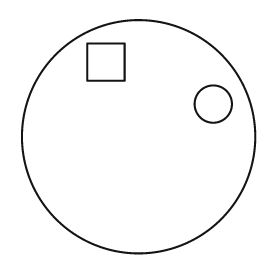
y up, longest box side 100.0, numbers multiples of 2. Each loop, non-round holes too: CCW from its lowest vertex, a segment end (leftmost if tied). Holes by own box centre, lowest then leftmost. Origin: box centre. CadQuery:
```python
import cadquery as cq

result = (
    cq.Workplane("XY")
    .moveTo(0.0, 0.0)
    .circle(50.0)
    .moveTo(32.0, 14.0)
    .circle(8.0)
    .moveTo(-22.0, 24.0)
    .lineTo(-6.0, 24.0)
    .lineTo(-6.0, 40.0)
    .lineTo(-22.0, 40.0)
    .close()
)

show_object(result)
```